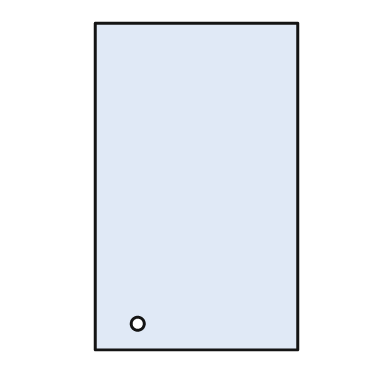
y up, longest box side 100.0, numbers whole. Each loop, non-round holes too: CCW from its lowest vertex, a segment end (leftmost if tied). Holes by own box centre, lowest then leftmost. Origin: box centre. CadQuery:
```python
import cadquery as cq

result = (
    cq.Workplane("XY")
    .moveTo(-31.0, -50.0)
    .lineTo(31.0, -50.0)
    .lineTo(31.0, 50.0)
    .lineTo(-31.0, 50.0)
    .close()
    .moveTo(-18.0, -42.0)
    .circle(2.0)
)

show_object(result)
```